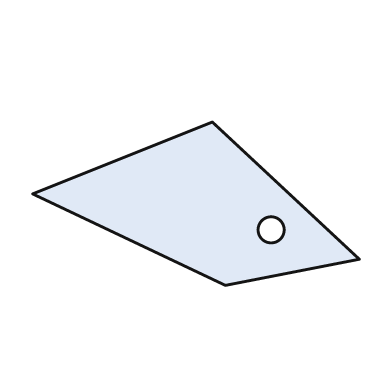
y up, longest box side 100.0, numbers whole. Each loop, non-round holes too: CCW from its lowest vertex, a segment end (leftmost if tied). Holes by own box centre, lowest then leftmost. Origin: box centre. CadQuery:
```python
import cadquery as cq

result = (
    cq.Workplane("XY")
    .moveTo(9.0, -25.0)
    .lineTo(50.0, -17.0)
    .lineTo(5.0, 25.0)
    .lineTo(-50.0, 3.0)
    .close()
    .moveTo(23.0, -8.0)
    .circle(4.0)
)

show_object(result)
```